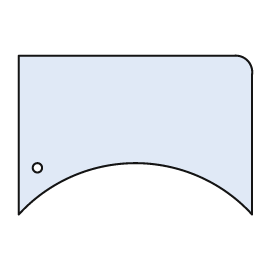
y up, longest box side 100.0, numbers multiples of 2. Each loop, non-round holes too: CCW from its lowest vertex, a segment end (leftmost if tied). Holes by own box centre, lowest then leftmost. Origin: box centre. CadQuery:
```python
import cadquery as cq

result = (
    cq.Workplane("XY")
    .moveTo(-50.0, -34.0)
    .threePointArc((0.0, -12.0), (50.0, -34.0))
    .lineTo(50.0, 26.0)
    .threePointArc((48.0, 32.0), (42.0, 34.0))
    .lineTo(-50.0, 34.0)
    .close()
    .moveTo(-42.0, -14.0)
    .circle(2.0)
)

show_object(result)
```